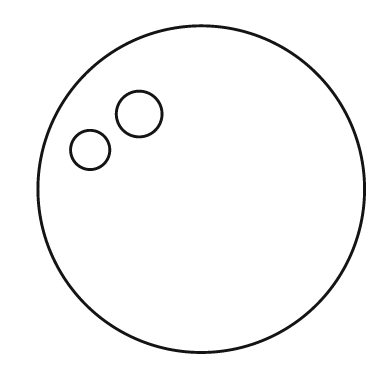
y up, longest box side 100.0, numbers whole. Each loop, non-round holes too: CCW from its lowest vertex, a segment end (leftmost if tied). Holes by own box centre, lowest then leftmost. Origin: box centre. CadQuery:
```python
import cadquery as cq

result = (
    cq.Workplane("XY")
    .moveTo(0.0, 0.0)
    .circle(50.0)
    .moveTo(-34.0, 12.0)
    .circle(6.0)
    .moveTo(-19.0, 23.0)
    .circle(7.0)
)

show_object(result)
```